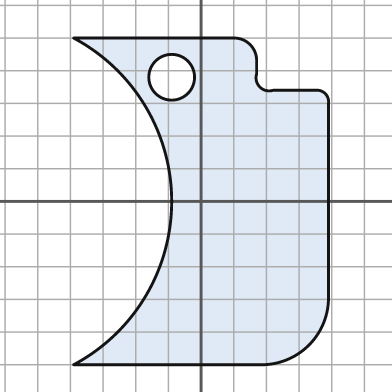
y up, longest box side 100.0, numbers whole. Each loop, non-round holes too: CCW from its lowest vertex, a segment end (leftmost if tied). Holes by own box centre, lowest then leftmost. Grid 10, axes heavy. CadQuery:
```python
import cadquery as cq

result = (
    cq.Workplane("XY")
    .moveTo(-39.0, -50.0)
    .lineTo(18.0, -50.0)
    .threePointArc((33.0, -44.0), (39.0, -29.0))
    .lineTo(39.0, 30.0)
    .threePointArc((38.0, 33.0), (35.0, 34.0))
    .lineTo(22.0, 34.0)
    .threePointArc((18.0, 35.0), (17.0, 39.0))
    .lineTo(17.0, 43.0)
    .threePointArc((15.0, 48.0), (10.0, 50.0))
    .lineTo(-39.0, 50.0)
    .threePointArc((-9.0, 0.0), (-39.0, -50.0))
    .close()
    .moveTo(-9.0, 38.0)
    .circle(7.0)
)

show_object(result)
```